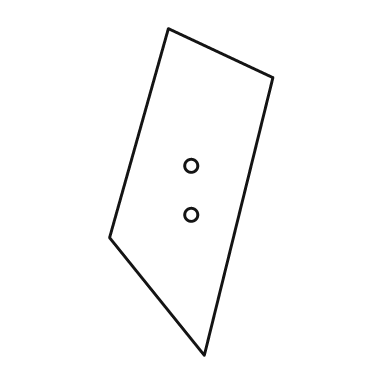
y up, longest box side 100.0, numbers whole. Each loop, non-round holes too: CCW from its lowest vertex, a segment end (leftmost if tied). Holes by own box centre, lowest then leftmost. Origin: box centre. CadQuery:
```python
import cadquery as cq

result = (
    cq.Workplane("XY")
    .moveTo(4.0, -50.0)
    .lineTo(25.0, 35.0)
    .lineTo(-7.0, 50.0)
    .lineTo(-25.0, -14.0)
    .close()
    .moveTo(0.0, -7.0)
    .circle(2.0)
    .moveTo(0.0, 8.0)
    .circle(2.0)
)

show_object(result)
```